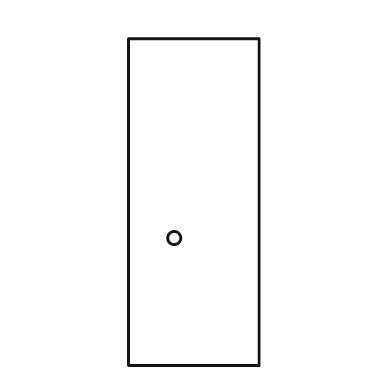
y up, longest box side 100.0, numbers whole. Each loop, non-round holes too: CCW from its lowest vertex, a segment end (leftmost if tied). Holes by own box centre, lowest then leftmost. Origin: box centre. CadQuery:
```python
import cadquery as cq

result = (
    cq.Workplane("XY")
    .moveTo(-20.0, -50.0)
    .lineTo(20.0, -50.0)
    .lineTo(20.0, 50.0)
    .lineTo(-20.0, 50.0)
    .close()
    .moveTo(-6.0, -11.0)
    .circle(2.0)
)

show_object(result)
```